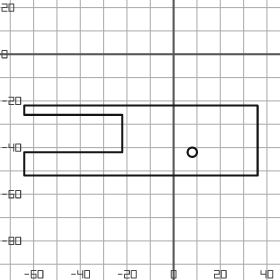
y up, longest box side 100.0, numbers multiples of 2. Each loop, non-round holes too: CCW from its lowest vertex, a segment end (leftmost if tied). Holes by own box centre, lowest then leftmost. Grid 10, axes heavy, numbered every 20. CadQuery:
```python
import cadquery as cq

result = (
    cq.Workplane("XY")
    .moveTo(-64.0, -52.0)
    .lineTo(36.0, -52.0)
    .lineTo(36.0, -22.0)
    .lineTo(-64.0, -22.0)
    .lineTo(-64.0, -26.0)
    .lineTo(-22.0, -26.0)
    .lineTo(-22.0, -42.0)
    .lineTo(-64.0, -42.0)
    .close()
    .moveTo(8.0, -42.0)
    .circle(2.0)
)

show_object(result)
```